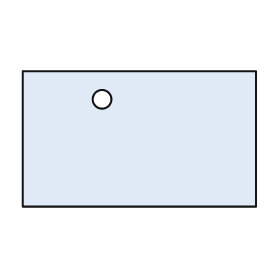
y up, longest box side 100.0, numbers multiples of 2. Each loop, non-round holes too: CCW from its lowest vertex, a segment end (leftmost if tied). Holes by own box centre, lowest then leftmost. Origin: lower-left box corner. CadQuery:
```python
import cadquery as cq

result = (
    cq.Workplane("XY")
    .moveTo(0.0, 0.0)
    .lineTo(100.0, 0.0)
    .lineTo(100.0, 58.0)
    .lineTo(0.0, 58.0)
    .close()
    .moveTo(34.0, 46.0)
    .circle(4.0)
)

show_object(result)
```